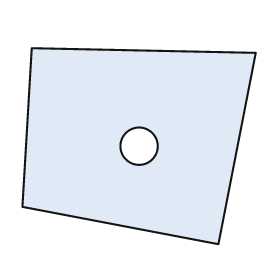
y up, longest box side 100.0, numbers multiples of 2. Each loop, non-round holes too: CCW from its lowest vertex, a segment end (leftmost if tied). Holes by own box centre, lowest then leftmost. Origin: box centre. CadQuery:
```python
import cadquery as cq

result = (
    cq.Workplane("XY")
    .moveTo(34.0, -42.0)
    .lineTo(50.0, 40.0)
    .lineTo(-46.0, 42.0)
    .lineTo(-50.0, -26.0)
    .close()
    .moveTo(0.0, 0.0)
    .circle(8.0)
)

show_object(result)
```